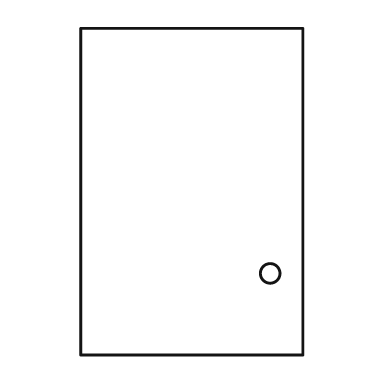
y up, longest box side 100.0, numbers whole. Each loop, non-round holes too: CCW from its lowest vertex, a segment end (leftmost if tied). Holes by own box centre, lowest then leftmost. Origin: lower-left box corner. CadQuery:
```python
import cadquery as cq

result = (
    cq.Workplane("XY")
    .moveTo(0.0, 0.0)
    .lineTo(68.0, 0.0)
    .lineTo(68.0, 100.0)
    .lineTo(0.0, 100.0)
    .close()
    .moveTo(58.0, 25.0)
    .circle(3.0)
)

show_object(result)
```